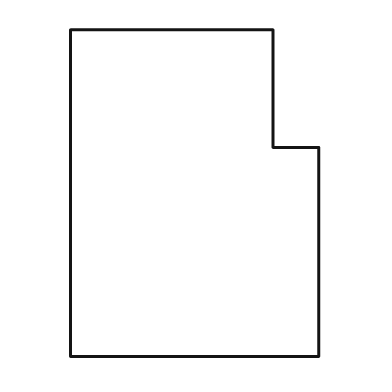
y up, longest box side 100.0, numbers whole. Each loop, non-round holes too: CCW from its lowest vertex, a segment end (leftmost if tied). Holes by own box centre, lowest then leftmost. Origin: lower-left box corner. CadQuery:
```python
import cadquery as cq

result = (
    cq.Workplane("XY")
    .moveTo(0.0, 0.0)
    .lineTo(76.0, 0.0)
    .lineTo(76.0, 64.0)
    .lineTo(62.0, 64.0)
    .lineTo(62.0, 100.0)
    .lineTo(0.0, 100.0)
    .close()
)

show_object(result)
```